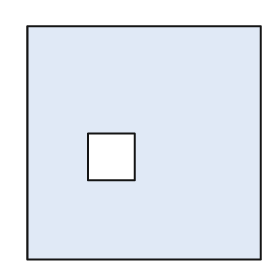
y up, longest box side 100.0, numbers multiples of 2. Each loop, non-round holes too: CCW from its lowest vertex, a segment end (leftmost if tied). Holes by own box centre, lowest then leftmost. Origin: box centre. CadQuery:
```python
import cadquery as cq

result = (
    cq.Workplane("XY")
    .moveTo(-50.0, -50.0)
    .lineTo(50.0, -50.0)
    .lineTo(50.0, 50.0)
    .lineTo(-50.0, 50.0)
    .close()
    .moveTo(-24.0, -16.0)
    .lineTo(-4.0, -16.0)
    .lineTo(-4.0, 4.0)
    .lineTo(-24.0, 4.0)
    .close()
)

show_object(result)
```